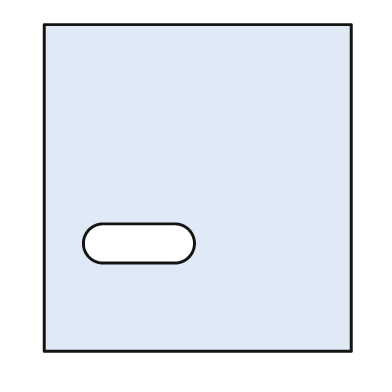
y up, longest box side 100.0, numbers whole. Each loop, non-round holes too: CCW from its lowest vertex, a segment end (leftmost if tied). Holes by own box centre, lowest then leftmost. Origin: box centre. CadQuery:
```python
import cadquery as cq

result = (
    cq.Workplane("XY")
    .moveTo(-47.0, -50.0)
    .lineTo(47.0, -50.0)
    .lineTo(47.0, 50.0)
    .lineTo(-47.0, 50.0)
    .close()
    .moveTo(-29.0, -23.0)
    .lineTo(-7.0, -23.0)
    .threePointArc((-1.0, -17.0), (-7.0, -11.0))
    .lineTo(-29.0, -11.0)
    .threePointArc((-35.0, -17.0), (-29.0, -23.0))
    .close()
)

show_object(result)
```